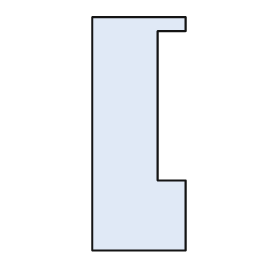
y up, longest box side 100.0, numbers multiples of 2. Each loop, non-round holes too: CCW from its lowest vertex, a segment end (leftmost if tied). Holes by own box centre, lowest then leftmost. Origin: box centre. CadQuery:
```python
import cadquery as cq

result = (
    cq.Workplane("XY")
    .moveTo(-20.0, -50.0)
    .lineTo(20.0, -50.0)
    .lineTo(20.0, -20.0)
    .lineTo(8.0, -20.0)
    .lineTo(8.0, 44.0)
    .lineTo(20.0, 44.0)
    .lineTo(20.0, 50.0)
    .lineTo(-20.0, 50.0)
    .close()
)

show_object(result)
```